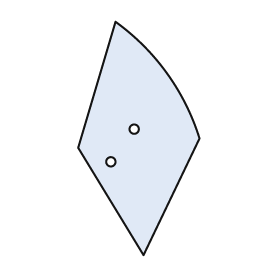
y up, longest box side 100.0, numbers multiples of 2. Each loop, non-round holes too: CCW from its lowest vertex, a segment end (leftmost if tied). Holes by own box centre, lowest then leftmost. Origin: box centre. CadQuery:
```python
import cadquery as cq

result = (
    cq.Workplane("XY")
    .moveTo(2.0, -50.0)
    .lineTo(26.0, 0.0)
    .threePointArc((12.0, 28.0), (-10.0, 50.0))
    .lineTo(-26.0, -4.0)
    .close()
    .moveTo(-12.0, -10.0)
    .circle(2.0)
    .moveTo(-2.0, 4.0)
    .circle(2.0)
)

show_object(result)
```